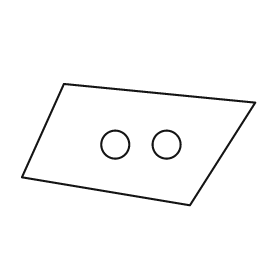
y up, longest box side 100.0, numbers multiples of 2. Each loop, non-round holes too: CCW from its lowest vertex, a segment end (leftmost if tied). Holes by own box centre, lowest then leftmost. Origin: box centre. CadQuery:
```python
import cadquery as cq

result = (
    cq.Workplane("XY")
    .moveTo(22.0, -26.0)
    .lineTo(50.0, 18.0)
    .lineTo(-32.0, 26.0)
    .lineTo(-50.0, -14.0)
    .close()
    .moveTo(-10.0, 0.0)
    .circle(6.0)
    .moveTo(12.0, 0.0)
    .circle(6.0)
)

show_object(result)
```